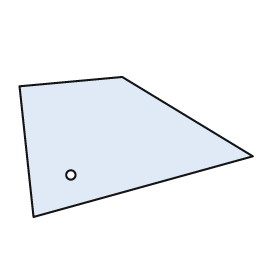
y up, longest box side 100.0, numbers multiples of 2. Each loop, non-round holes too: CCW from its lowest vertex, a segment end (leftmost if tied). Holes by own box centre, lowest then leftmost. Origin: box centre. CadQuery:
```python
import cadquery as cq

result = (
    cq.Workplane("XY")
    .moveTo(-44.0, -30.0)
    .lineTo(50.0, -4.0)
    .lineTo(-6.0, 30.0)
    .lineTo(-50.0, 26.0)
    .close()
    .moveTo(-28.0, -12.0)
    .circle(2.0)
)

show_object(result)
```